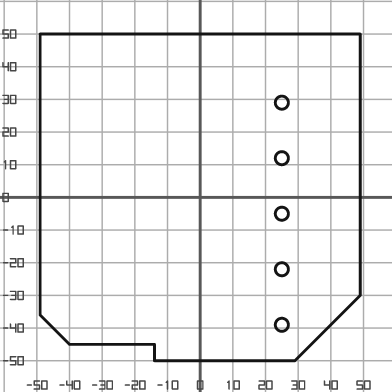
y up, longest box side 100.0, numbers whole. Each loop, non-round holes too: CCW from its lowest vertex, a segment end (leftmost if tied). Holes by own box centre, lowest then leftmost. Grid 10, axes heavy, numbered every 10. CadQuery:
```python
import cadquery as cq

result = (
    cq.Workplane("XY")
    .moveTo(-14.0, -50.0)
    .lineTo(29.0, -50.0)
    .lineTo(49.0, -30.0)
    .lineTo(49.0, 50.0)
    .lineTo(-49.0, 50.0)
    .lineTo(-49.0, -36.0)
    .lineTo(-40.0, -45.0)
    .lineTo(-14.0, -45.0)
    .close()
    .moveTo(25.0, -39.0)
    .circle(2.0)
    .moveTo(25.0, -22.0)
    .circle(2.0)
    .moveTo(25.0, -5.0)
    .circle(2.0)
    .moveTo(25.0, 12.0)
    .circle(2.0)
    .moveTo(25.0, 29.0)
    .circle(2.0)
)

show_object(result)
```